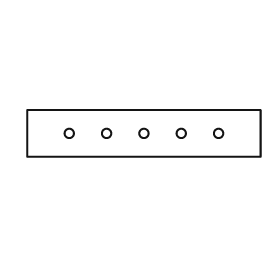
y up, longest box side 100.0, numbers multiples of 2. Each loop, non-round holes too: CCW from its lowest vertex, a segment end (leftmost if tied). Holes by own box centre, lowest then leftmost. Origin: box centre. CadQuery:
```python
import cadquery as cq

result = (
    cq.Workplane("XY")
    .moveTo(-50.0, -10.0)
    .lineTo(50.0, -10.0)
    .lineTo(50.0, 10.0)
    .lineTo(-50.0, 10.0)
    .close()
    .moveTo(-32.0, 0.0)
    .circle(2.0)
    .moveTo(-16.0, 0.0)
    .circle(2.0)
    .moveTo(0.0, 0.0)
    .circle(2.0)
    .moveTo(16.0, 0.0)
    .circle(2.0)
    .moveTo(32.0, 0.0)
    .circle(2.0)
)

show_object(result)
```